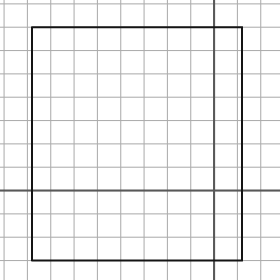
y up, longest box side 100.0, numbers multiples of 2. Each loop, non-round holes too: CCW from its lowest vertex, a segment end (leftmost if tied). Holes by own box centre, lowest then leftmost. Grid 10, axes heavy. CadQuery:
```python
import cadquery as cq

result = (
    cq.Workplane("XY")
    .moveTo(-78.0, -30.0)
    .lineTo(12.0, -30.0)
    .lineTo(12.0, 70.0)
    .lineTo(-78.0, 70.0)
    .close()
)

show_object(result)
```